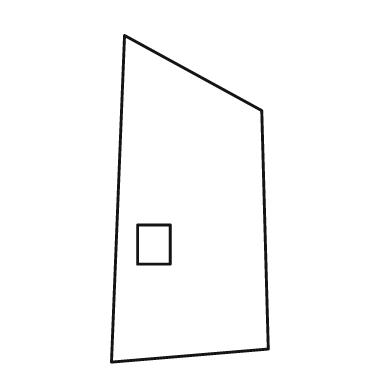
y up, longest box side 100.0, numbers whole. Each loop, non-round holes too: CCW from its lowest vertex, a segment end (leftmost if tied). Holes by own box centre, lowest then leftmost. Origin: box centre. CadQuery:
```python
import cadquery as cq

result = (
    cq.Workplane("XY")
    .moveTo(-24.0, -50.0)
    .lineTo(24.0, -46.0)
    .lineTo(22.0, 27.0)
    .lineTo(-20.0, 50.0)
    .close()
    .moveTo(-16.0, -20.0)
    .lineTo(-6.0, -20.0)
    .lineTo(-6.0, -8.0)
    .lineTo(-16.0, -8.0)
    .close()
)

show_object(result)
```